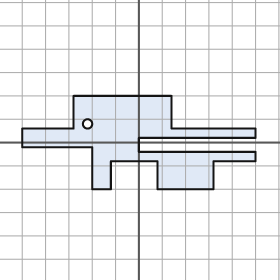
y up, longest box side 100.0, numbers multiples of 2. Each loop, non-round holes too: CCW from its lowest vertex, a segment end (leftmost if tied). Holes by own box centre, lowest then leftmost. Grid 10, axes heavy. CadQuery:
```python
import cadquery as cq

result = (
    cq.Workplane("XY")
    .moveTo(-20.0, -20.0)
    .lineTo(-12.0, -20.0)
    .lineTo(-12.0, -8.0)
    .lineTo(8.0, -8.0)
    .lineTo(8.0, -20.0)
    .lineTo(32.0, -20.0)
    .lineTo(32.0, -8.0)
    .lineTo(50.0, -8.0)
    .lineTo(50.0, -4.0)
    .lineTo(0.0, -4.0)
    .lineTo(0.0, 2.0)
    .lineTo(50.0, 2.0)
    .lineTo(50.0, 6.0)
    .lineTo(14.0, 6.0)
    .lineTo(14.0, 20.0)
    .lineTo(-28.0, 20.0)
    .lineTo(-28.0, 6.0)
    .lineTo(-50.0, 6.0)
    .lineTo(-50.0, -2.0)
    .lineTo(-20.0, -2.0)
    .close()
    .moveTo(-22.0, 8.0)
    .circle(2.0)
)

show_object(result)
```